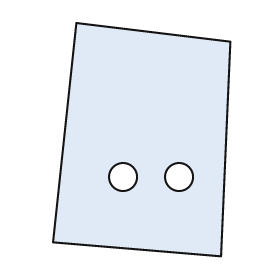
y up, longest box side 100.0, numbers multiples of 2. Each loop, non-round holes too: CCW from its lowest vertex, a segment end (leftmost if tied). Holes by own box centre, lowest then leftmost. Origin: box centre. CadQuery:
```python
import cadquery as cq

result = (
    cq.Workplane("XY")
    .moveTo(34.0, -50.0)
    .lineTo(38.0, 42.0)
    .lineTo(-28.0, 50.0)
    .lineTo(-38.0, -44.0)
    .close()
    .moveTo(-8.0, -16.0)
    .circle(6.0)
    .moveTo(16.0, -16.0)
    .circle(6.0)
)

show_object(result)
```